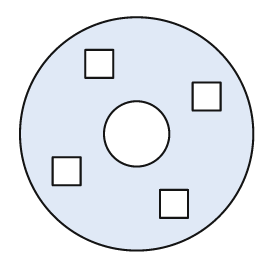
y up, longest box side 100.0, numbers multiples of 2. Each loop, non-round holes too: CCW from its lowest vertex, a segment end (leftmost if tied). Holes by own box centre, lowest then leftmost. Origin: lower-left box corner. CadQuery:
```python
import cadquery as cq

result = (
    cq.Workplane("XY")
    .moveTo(50.0, 50.0)
    .circle(50.0)
    .moveTo(60.0, 14.0)
    .lineTo(72.0, 14.0)
    .lineTo(72.0, 26.0)
    .lineTo(60.0, 26.0)
    .close()
    .moveTo(14.0, 28.0)
    .lineTo(26.0, 28.0)
    .lineTo(26.0, 40.0)
    .lineTo(14.0, 40.0)
    .close()
    .moveTo(50.0, 50.0)
    .circle(14.0)
    .moveTo(74.0, 60.0)
    .lineTo(86.0, 60.0)
    .lineTo(86.0, 72.0)
    .lineTo(74.0, 72.0)
    .close()
    .moveTo(28.0, 74.0)
    .lineTo(40.0, 74.0)
    .lineTo(40.0, 86.0)
    .lineTo(28.0, 86.0)
    .close()
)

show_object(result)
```